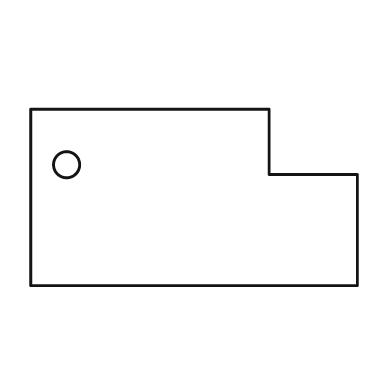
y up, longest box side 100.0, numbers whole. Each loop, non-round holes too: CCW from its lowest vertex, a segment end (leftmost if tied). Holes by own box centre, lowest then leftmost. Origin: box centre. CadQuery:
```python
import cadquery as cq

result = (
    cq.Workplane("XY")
    .moveTo(-50.0, -27.0)
    .lineTo(50.0, -27.0)
    .lineTo(50.0, 7.0)
    .lineTo(23.0, 7.0)
    .lineTo(23.0, 27.0)
    .lineTo(-50.0, 27.0)
    .close()
    .moveTo(-39.0, 10.0)
    .circle(4.0)
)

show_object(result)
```